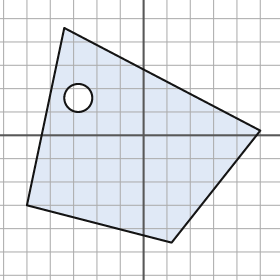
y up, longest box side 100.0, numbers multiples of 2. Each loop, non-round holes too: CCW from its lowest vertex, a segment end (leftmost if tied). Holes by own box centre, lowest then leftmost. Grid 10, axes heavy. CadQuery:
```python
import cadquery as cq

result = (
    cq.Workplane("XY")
    .moveTo(12.0, -46.0)
    .lineTo(50.0, 2.0)
    .lineTo(-34.0, 46.0)
    .lineTo(-50.0, -30.0)
    .close()
    .moveTo(-28.0, 16.0)
    .circle(6.0)
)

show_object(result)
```